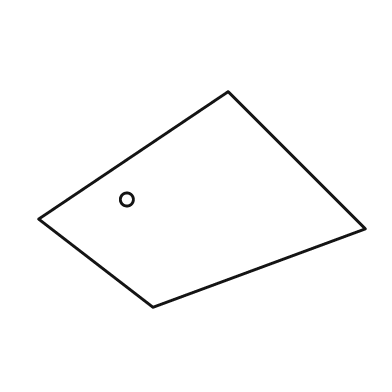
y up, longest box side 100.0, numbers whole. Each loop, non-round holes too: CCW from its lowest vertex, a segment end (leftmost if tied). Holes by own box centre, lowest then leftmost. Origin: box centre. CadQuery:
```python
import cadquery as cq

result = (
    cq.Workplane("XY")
    .moveTo(-15.0, -33.0)
    .lineTo(50.0, -9.0)
    .lineTo(8.0, 33.0)
    .lineTo(-50.0, -6.0)
    .close()
    .moveTo(-23.0, 0.0)
    .circle(2.0)
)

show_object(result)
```